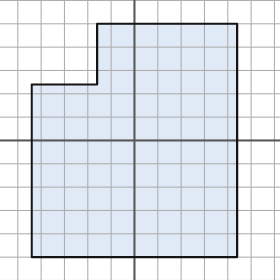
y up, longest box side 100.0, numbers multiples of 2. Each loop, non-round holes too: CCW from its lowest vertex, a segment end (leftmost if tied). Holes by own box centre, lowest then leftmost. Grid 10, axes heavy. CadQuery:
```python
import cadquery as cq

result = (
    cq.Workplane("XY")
    .moveTo(-44.0, -50.0)
    .lineTo(44.0, -50.0)
    .lineTo(44.0, 50.0)
    .lineTo(-16.0, 50.0)
    .lineTo(-16.0, 24.0)
    .lineTo(-44.0, 24.0)
    .close()
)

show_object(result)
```